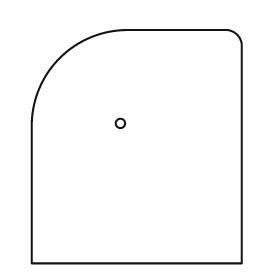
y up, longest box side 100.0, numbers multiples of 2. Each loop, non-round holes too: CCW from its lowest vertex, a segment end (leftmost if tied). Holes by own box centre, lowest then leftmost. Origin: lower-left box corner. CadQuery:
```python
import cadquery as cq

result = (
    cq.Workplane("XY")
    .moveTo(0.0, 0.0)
    .lineTo(90.0, 0.0)
    .lineTo(90.0, 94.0)
    .threePointArc((88.0, 98.0), (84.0, 100.0))
    .lineTo(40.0, 100.0)
    .threePointArc((12.0, 88.0), (0.0, 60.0))
    .close()
    .moveTo(38.0, 60.0)
    .circle(2.0)
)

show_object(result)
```